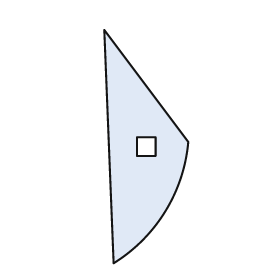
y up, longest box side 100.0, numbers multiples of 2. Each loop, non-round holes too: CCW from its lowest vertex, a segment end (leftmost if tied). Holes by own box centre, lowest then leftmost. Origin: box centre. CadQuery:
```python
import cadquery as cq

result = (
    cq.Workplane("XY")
    .moveTo(-14.0, -50.0)
    .threePointArc((8.0, -28.0), (18.0, 2.0))
    .lineTo(-18.0, 50.0)
    .close()
    .moveTo(-4.0, -4.0)
    .lineTo(4.0, -4.0)
    .lineTo(4.0, 4.0)
    .lineTo(-4.0, 4.0)
    .close()
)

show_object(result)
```